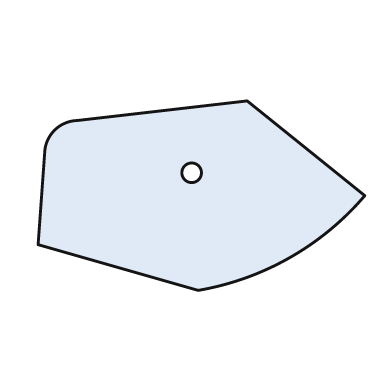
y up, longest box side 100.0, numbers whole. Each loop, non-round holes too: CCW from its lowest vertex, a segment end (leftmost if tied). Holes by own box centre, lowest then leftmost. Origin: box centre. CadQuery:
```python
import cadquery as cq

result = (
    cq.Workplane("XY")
    .moveTo(-1.0, -29.0)
    .threePointArc((27.0, -19.0), (50.0, 0.0))
    .lineTo(14.0, 29.0)
    .lineTo(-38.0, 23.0)
    .threePointArc((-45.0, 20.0), (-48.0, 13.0))
    .lineTo(-50.0, -15.0)
    .close()
    .moveTo(-3.0, 7.0)
    .circle(3.0)
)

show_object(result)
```